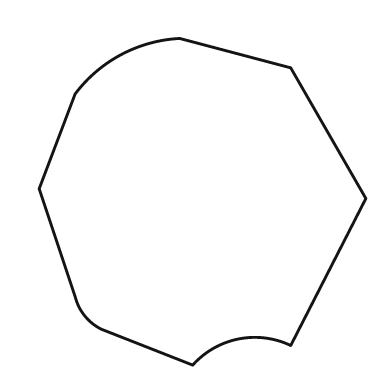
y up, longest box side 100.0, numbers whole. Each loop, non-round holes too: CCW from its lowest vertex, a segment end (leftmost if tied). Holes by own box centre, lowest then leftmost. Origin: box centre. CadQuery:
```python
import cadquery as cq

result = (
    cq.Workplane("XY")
    .moveTo(-3.0, -50.0)
    .threePointArc((11.0, -42.0), (27.0, -44.0))
    .lineTo(50.0, 1.0)
    .lineTo(27.0, 41.0)
    .lineTo(-7.0, 50.0)
    .threePointArc((-25.0, 45.0), (-39.0, 33.0))
    .lineTo(-50.0, 4.0)
    .lineTo(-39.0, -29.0)
    .threePointArc((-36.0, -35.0), (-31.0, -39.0))
    .close()
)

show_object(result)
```